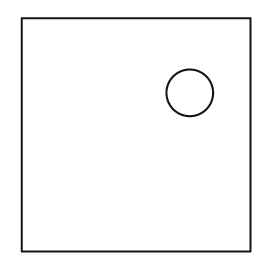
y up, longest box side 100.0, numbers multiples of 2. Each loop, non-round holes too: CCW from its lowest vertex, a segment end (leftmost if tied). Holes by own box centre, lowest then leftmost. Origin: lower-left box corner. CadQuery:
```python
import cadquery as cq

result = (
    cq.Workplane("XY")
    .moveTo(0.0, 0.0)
    .lineTo(98.0, 0.0)
    .lineTo(98.0, 100.0)
    .lineTo(0.0, 100.0)
    .close()
    .moveTo(72.0, 68.0)
    .circle(10.0)
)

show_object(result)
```